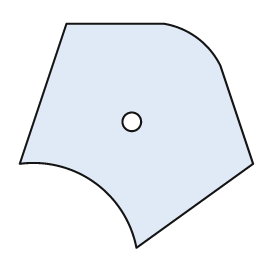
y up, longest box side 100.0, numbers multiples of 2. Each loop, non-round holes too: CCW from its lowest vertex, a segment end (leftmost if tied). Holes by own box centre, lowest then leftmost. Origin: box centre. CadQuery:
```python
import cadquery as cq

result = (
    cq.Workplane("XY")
    .moveTo(0.0, -48.0)
    .lineTo(50.0, -12.0)
    .lineTo(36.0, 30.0)
    .threePointArc((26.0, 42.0), (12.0, 48.0))
    .lineTo(-30.0, 48.0)
    .lineTo(-50.0, -12.0)
    .threePointArc((-18.0, -20.0), (0.0, -48.0))
    .close()
    .moveTo(-2.0, 6.0)
    .circle(4.0)
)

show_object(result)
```